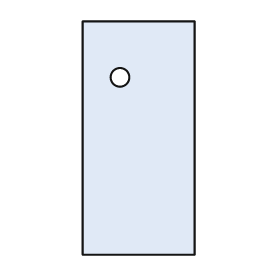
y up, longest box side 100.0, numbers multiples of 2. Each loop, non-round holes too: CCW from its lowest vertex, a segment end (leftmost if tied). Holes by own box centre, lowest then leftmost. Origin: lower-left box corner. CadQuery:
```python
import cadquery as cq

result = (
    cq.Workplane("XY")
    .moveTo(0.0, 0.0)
    .lineTo(48.0, 0.0)
    .lineTo(48.0, 100.0)
    .lineTo(0.0, 100.0)
    .close()
    .moveTo(16.0, 76.0)
    .circle(4.0)
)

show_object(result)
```